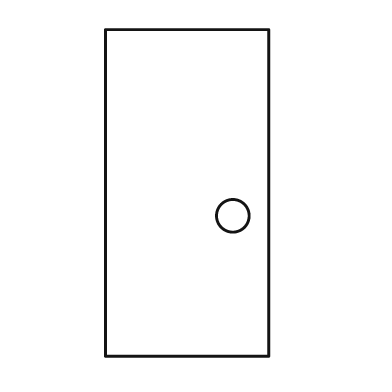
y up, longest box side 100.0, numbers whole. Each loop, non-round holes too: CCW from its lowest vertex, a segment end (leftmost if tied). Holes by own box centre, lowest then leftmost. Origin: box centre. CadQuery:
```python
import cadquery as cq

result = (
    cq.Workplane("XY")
    .moveTo(-25.0, -50.0)
    .lineTo(25.0, -50.0)
    .lineTo(25.0, 50.0)
    .lineTo(-25.0, 50.0)
    .close()
    .moveTo(14.0, -7.0)
    .circle(5.0)
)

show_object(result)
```